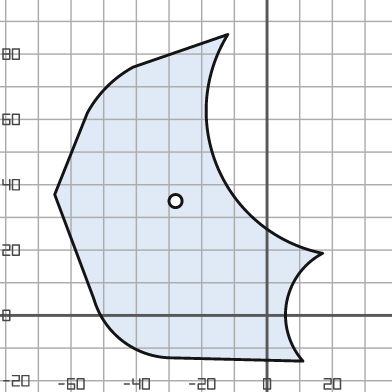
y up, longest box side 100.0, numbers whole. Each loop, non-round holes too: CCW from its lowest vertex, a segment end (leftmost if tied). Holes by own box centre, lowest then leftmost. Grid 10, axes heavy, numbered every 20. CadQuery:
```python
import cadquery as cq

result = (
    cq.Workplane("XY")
    .moveTo(11.0, -14.0)
    .threePointArc((6.0, 4.0), (17.0, 19.0))
    .threePointArc((-15.0, 45.0), (-12.0, 86.0))
    .lineTo(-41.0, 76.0)
    .threePointArc((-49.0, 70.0), (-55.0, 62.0))
    .lineTo(-65.0, 37.0)
    .lineTo(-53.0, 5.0)
    .threePointArc((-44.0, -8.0), (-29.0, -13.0))
    .close()
    .moveTo(-28.0, 35.0)
    .circle(2.0)
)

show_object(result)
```